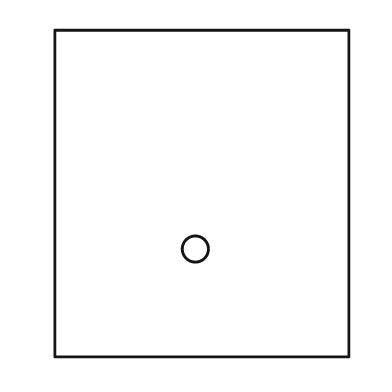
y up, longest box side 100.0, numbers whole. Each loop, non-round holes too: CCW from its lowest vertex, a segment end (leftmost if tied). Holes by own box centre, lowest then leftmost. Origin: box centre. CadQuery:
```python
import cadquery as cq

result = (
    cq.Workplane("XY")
    .moveTo(-45.0, -50.0)
    .lineTo(45.0, -50.0)
    .lineTo(45.0, 50.0)
    .lineTo(-45.0, 50.0)
    .close()
    .moveTo(-2.0, -17.0)
    .circle(4.0)
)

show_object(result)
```